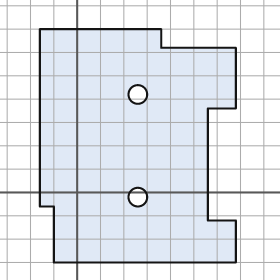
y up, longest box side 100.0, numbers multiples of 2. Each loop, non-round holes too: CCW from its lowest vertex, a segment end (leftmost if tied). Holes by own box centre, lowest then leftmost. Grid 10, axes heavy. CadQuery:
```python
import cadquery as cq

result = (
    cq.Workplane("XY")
    .moveTo(-10.0, -30.0)
    .lineTo(68.0, -30.0)
    .lineTo(68.0, -12.0)
    .lineTo(56.0, -12.0)
    .lineTo(56.0, 36.0)
    .lineTo(68.0, 36.0)
    .lineTo(68.0, 62.0)
    .lineTo(36.0, 62.0)
    .lineTo(36.0, 70.0)
    .lineTo(-16.0, 70.0)
    .lineTo(-16.0, -6.0)
    .lineTo(-10.0, -6.0)
    .close()
    .moveTo(26.0, -2.0)
    .circle(4.0)
    .moveTo(26.0, 42.0)
    .circle(4.0)
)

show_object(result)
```